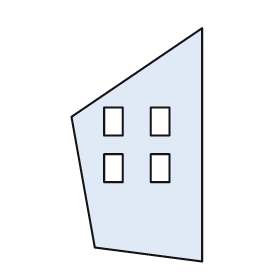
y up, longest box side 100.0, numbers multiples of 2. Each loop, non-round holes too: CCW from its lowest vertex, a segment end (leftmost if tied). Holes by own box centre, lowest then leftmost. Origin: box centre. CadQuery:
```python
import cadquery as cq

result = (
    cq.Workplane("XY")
    .moveTo(28.0, -50.0)
    .lineTo(28.0, 50.0)
    .lineTo(-28.0, 12.0)
    .lineTo(-18.0, -44.0)
    .close()
    .moveTo(-14.0, -16.0)
    .lineTo(-6.0, -16.0)
    .lineTo(-6.0, -4.0)
    .lineTo(-14.0, -4.0)
    .close()
    .moveTo(6.0, -16.0)
    .lineTo(14.0, -16.0)
    .lineTo(14.0, -4.0)
    .lineTo(6.0, -4.0)
    .close()
    .moveTo(-14.0, 4.0)
    .lineTo(-6.0, 4.0)
    .lineTo(-6.0, 16.0)
    .lineTo(-14.0, 16.0)
    .close()
    .moveTo(6.0, 4.0)
    .lineTo(14.0, 4.0)
    .lineTo(14.0, 16.0)
    .lineTo(6.0, 16.0)
    .close()
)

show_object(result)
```